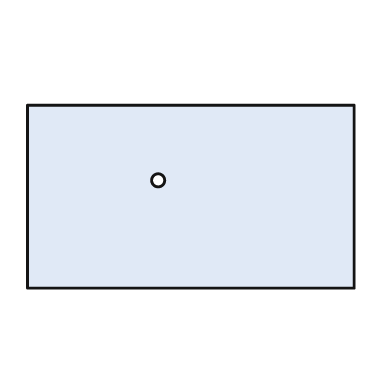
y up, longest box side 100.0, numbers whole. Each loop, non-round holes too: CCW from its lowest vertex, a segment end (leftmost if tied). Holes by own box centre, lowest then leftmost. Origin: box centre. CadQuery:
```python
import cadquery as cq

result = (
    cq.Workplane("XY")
    .moveTo(-50.0, -28.0)
    .lineTo(50.0, -28.0)
    .lineTo(50.0, 28.0)
    .lineTo(-50.0, 28.0)
    .close()
    .moveTo(-10.0, 5.0)
    .circle(2.0)
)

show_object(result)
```